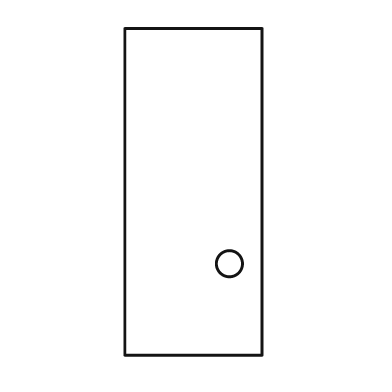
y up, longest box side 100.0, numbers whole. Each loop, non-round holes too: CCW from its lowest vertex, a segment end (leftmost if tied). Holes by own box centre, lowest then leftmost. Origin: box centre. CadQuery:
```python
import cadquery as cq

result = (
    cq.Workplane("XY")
    .moveTo(-21.0, -50.0)
    .lineTo(21.0, -50.0)
    .lineTo(21.0, 50.0)
    .lineTo(-21.0, 50.0)
    .close()
    .moveTo(11.0, -22.0)
    .circle(4.0)
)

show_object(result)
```